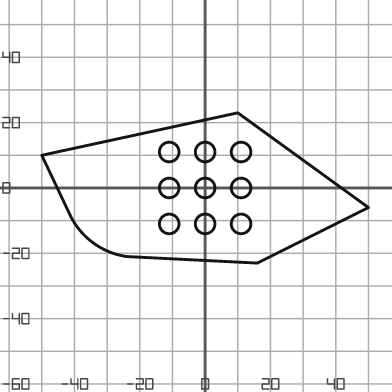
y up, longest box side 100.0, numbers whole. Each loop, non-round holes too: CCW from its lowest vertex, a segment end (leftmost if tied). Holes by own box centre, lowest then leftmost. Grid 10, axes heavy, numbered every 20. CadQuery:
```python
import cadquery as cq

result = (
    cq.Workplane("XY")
    .moveTo(16.0, -23.0)
    .lineTo(50.0, -6.0)
    .lineTo(10.0, 23.0)
    .lineTo(-50.0, 10.0)
    .lineTo(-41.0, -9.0)
    .threePointArc((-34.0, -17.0), (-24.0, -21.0))
    .close()
    .moveTo(-11.0, -11.0)
    .circle(3.0)
    .moveTo(0.0, -11.0)
    .circle(3.0)
    .moveTo(11.0, -11.0)
    .circle(3.0)
    .moveTo(-11.0, 0.0)
    .circle(3.0)
    .moveTo(0.0, 0.0)
    .circle(3.0)
    .moveTo(11.0, 0.0)
    .circle(3.0)
    .moveTo(-11.0, 11.0)
    .circle(3.0)
    .moveTo(0.0, 11.0)
    .circle(3.0)
    .moveTo(11.0, 11.0)
    .circle(3.0)
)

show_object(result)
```